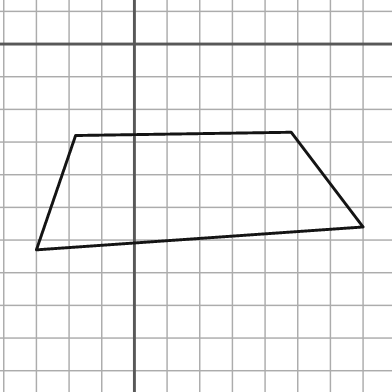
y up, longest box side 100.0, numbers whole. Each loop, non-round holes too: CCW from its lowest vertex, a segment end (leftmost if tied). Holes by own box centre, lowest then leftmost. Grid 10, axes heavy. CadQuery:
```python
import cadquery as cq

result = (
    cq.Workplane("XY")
    .moveTo(-30.0, -63.0)
    .lineTo(70.0, -56.0)
    .lineTo(48.0, -27.0)
    .lineTo(-18.0, -28.0)
    .close()
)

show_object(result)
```